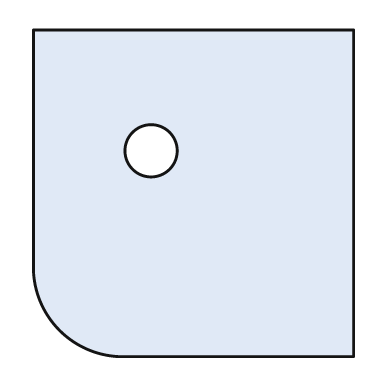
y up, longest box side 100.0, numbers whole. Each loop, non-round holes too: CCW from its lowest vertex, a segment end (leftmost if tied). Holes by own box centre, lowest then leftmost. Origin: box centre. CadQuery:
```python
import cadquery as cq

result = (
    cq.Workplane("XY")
    .moveTo(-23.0, -50.0)
    .lineTo(49.0, -50.0)
    .lineTo(49.0, 50.0)
    .lineTo(-49.0, 50.0)
    .lineTo(-49.0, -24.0)
    .threePointArc((-41.0, -42.0), (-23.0, -50.0))
    .close()
    .moveTo(-13.0, 13.0)
    .circle(8.0)
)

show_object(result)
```